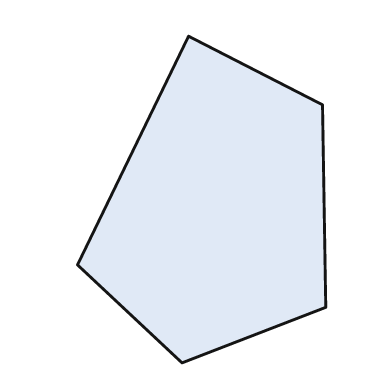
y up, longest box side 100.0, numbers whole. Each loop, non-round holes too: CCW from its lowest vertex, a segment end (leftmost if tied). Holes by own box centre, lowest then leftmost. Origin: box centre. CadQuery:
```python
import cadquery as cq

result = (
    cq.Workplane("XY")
    .moveTo(-6.0, -50.0)
    .lineTo(38.0, -33.0)
    .lineTo(37.0, 29.0)
    .lineTo(-4.0, 50.0)
    .lineTo(-38.0, -20.0)
    .close()
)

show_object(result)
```